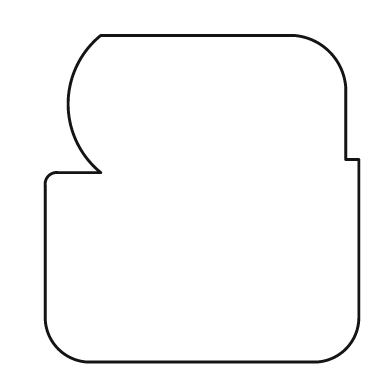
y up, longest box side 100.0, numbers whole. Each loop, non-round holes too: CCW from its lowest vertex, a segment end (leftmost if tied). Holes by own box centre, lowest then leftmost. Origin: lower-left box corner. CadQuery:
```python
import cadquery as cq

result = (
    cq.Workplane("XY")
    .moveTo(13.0, 0.0)
    .lineTo(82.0, 0.0)
    .threePointArc((92.0, 4.0), (96.0, 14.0))
    .lineTo(96.0, 62.0)
    .lineTo(92.0, 62.0)
    .lineTo(92.0, 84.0)
    .threePointArc((87.0, 95.0), (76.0, 100.0))
    .lineTo(17.0, 100.0)
    .threePointArc((7.0, 79.0), (17.0, 58.0))
    .lineTo(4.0, 58.0)
    .threePointArc((1.0, 57.0), (0.0, 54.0))
    .lineTo(0.0, 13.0)
    .threePointArc((4.0, 4.0), (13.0, 0.0))
    .close()
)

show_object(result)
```